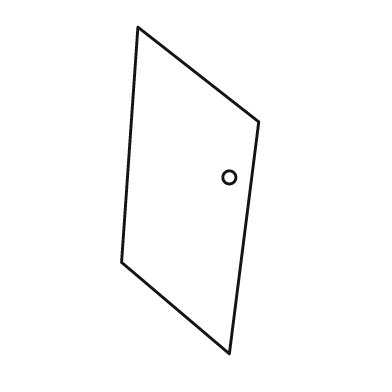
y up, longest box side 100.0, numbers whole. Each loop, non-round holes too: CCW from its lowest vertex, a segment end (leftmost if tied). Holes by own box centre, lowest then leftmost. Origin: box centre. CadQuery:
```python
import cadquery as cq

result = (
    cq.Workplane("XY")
    .moveTo(12.0, -50.0)
    .lineTo(21.0, 21.0)
    .lineTo(-16.0, 50.0)
    .lineTo(-21.0, -22.0)
    .close()
    .moveTo(12.0, 4.0)
    .circle(2.0)
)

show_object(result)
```